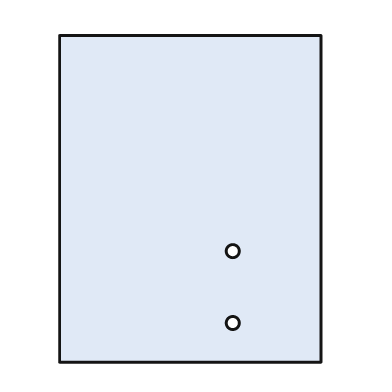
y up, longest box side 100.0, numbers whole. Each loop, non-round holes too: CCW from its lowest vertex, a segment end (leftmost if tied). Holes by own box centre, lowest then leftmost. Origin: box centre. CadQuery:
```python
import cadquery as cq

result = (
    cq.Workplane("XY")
    .moveTo(-40.0, -50.0)
    .lineTo(40.0, -50.0)
    .lineTo(40.0, 50.0)
    .lineTo(-40.0, 50.0)
    .close()
    .moveTo(13.0, -38.0)
    .circle(2.0)
    .moveTo(13.0, -16.0)
    .circle(2.0)
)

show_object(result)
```